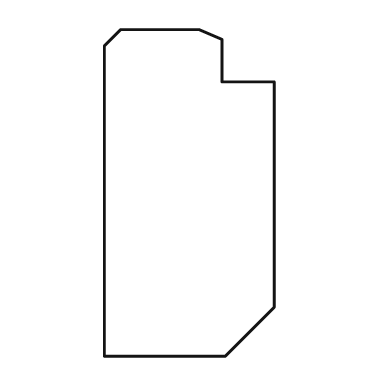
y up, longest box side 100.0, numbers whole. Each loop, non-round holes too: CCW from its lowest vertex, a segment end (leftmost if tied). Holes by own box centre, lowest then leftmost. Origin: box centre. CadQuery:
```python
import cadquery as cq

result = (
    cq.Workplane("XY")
    .moveTo(-26.0, -50.0)
    .lineTo(11.0, -50.0)
    .lineTo(26.0, -35.0)
    .lineTo(26.0, 34.0)
    .lineTo(10.0, 34.0)
    .lineTo(10.0, 47.0)
    .lineTo(3.0, 50.0)
    .lineTo(-21.0, 50.0)
    .lineTo(-26.0, 45.0)
    .close()
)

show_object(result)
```